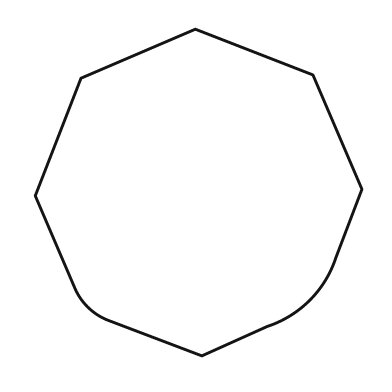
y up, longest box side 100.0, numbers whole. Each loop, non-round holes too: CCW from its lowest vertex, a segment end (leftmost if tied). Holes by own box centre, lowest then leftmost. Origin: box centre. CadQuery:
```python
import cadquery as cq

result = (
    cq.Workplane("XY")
    .moveTo(1.0, -50.0)
    .lineTo(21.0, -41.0)
    .threePointArc((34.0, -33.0), (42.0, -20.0))
    .lineTo(50.0, 1.0)
    .lineTo(35.0, 36.0)
    .lineTo(-1.0, 50.0)
    .lineTo(-36.0, 35.0)
    .lineTo(-50.0, -1.0)
    .lineTo(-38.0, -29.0)
    .threePointArc((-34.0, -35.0), (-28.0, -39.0))
    .close()
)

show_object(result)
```